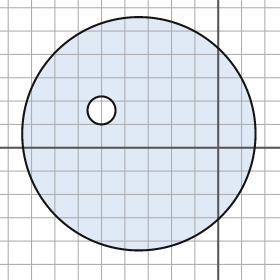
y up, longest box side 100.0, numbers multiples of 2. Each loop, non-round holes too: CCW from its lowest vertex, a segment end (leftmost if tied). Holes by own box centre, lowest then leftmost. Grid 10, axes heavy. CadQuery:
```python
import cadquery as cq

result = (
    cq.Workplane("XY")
    .moveTo(-34.0, 6.0)
    .circle(50.0)
    .moveTo(-50.0, 16.0)
    .circle(6.0)
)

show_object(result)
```